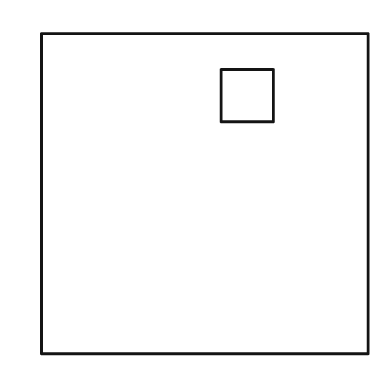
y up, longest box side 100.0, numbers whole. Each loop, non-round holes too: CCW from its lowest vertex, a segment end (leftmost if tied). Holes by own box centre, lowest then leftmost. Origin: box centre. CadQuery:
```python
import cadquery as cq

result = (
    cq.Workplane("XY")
    .moveTo(-50.0, -49.0)
    .lineTo(50.0, -49.0)
    .lineTo(50.0, 49.0)
    .lineTo(-50.0, 49.0)
    .close()
    .moveTo(5.0, 22.0)
    .lineTo(21.0, 22.0)
    .lineTo(21.0, 38.0)
    .lineTo(5.0, 38.0)
    .close()
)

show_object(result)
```